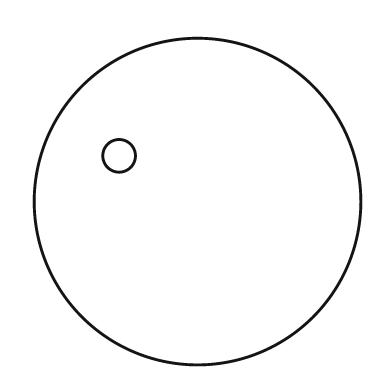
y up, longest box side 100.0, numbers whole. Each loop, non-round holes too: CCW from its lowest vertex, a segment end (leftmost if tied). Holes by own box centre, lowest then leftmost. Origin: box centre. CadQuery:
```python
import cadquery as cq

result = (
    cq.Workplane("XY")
    .moveTo(0.0, 0.0)
    .circle(50.0)
    .moveTo(-24.0, 14.0)
    .circle(5.0)
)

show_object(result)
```